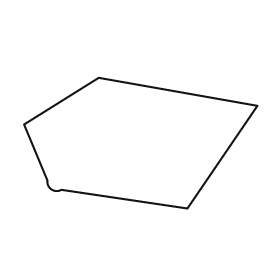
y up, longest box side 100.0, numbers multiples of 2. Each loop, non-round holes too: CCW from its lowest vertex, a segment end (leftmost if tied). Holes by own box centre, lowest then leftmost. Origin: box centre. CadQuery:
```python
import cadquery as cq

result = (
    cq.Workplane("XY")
    .moveTo(20.0, -28.0)
    .lineTo(50.0, 16.0)
    .lineTo(-18.0, 28.0)
    .lineTo(-50.0, 8.0)
    .lineTo(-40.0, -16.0)
    .threePointArc((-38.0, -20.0), (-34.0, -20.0))
    .close()
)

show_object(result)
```